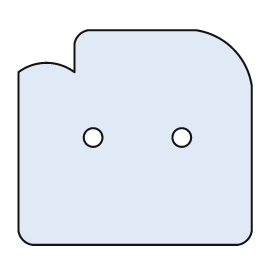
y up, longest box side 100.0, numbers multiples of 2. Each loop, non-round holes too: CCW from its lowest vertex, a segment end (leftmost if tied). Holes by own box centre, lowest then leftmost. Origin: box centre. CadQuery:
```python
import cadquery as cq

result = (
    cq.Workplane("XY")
    .moveTo(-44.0, -46.0)
    .lineTo(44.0, -46.0)
    .threePointArc((48.0, -44.0), (50.0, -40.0))
    .lineTo(50.0, 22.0)
    .threePointArc((42.0, 38.0), (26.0, 46.0))
    .lineTo(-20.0, 46.0)
    .threePointArc((-24.0, 44.0), (-26.0, 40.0))
    .lineTo(-26.0, 28.0)
    .threePointArc((-38.0, 32.0), (-50.0, 28.0))
    .lineTo(-50.0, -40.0)
    .threePointArc((-48.0, -44.0), (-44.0, -46.0))
    .close()
    .moveTo(-18.0, 0.0)
    .circle(4.0)
    .moveTo(20.0, 0.0)
    .circle(4.0)
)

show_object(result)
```